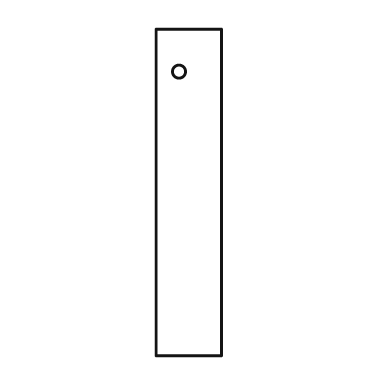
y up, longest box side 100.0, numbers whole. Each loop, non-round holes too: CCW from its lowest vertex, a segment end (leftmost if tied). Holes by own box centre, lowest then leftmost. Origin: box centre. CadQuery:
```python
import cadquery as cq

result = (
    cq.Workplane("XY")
    .moveTo(-10.0, -50.0)
    .lineTo(10.0, -50.0)
    .lineTo(10.0, 50.0)
    .lineTo(-10.0, 50.0)
    .close()
    .moveTo(-3.0, 37.0)
    .circle(2.0)
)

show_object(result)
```